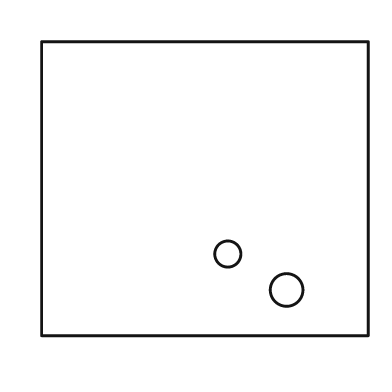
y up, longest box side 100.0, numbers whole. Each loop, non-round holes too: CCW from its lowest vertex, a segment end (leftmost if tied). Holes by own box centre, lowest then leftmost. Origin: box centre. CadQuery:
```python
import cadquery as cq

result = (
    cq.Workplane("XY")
    .moveTo(-50.0, -45.0)
    .lineTo(50.0, -45.0)
    .lineTo(50.0, 45.0)
    .lineTo(-50.0, 45.0)
    .close()
    .moveTo(25.0, -31.0)
    .circle(5.0)
    .moveTo(7.0, -20.0)
    .circle(4.0)
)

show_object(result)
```